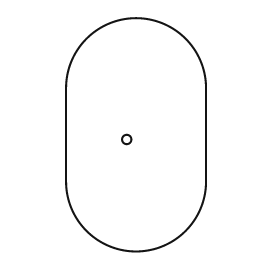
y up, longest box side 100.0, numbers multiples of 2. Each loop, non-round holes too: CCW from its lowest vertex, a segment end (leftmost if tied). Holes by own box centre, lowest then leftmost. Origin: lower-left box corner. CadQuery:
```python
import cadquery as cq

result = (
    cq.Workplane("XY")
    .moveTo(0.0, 30.0)
    .threePointArc((30.0, 0.0), (60.0, 30.0))
    .lineTo(60.0, 70.0)
    .threePointArc((30.0, 100.0), (0.0, 70.0))
    .close()
    .moveTo(26.0, 48.0)
    .circle(2.0)
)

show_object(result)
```